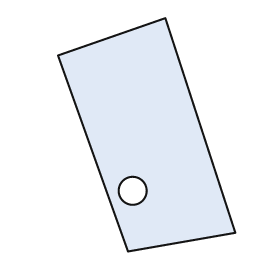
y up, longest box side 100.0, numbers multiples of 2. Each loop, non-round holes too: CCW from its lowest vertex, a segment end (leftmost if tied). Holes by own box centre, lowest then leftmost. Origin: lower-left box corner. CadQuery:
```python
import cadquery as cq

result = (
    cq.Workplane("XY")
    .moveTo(30.0, 0.0)
    .lineTo(76.0, 8.0)
    .lineTo(46.0, 100.0)
    .lineTo(0.0, 84.0)
    .close()
    .moveTo(32.0, 26.0)
    .circle(6.0)
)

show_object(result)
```